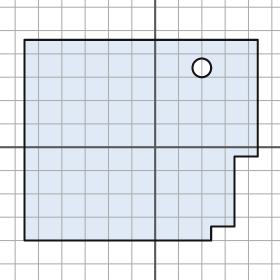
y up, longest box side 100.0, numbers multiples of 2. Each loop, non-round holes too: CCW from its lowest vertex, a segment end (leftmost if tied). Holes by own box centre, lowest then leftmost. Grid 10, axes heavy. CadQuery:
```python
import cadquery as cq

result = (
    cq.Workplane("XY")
    .moveTo(-56.0, -40.0)
    .lineTo(24.0, -40.0)
    .lineTo(24.0, -34.0)
    .lineTo(34.0, -34.0)
    .lineTo(34.0, -4.0)
    .lineTo(44.0, -4.0)
    .lineTo(44.0, 46.0)
    .lineTo(-56.0, 46.0)
    .close()
    .moveTo(20.0, 34.0)
    .circle(4.0)
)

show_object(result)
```